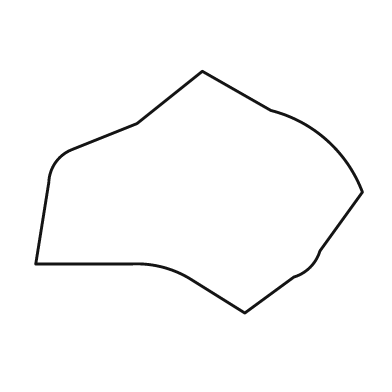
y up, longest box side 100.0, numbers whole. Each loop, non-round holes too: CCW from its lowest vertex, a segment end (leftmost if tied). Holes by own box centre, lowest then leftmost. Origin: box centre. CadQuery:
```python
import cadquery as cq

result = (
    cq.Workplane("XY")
    .moveTo(14.0, -37.0)
    .lineTo(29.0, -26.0)
    .threePointArc((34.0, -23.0), (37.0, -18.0))
    .lineTo(50.0, 0.0)
    .threePointArc((39.0, 16.0), (22.0, 25.0))
    .lineTo(1.0, 37.0)
    .lineTo(-19.0, 21.0)
    .lineTo(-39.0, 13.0)
    .threePointArc((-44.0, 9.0), (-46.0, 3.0))
    .lineTo(-50.0, -22.0)
    .lineTo(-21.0, -22.0)
    .threePointArc((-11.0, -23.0), (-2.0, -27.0))
    .close()
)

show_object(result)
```